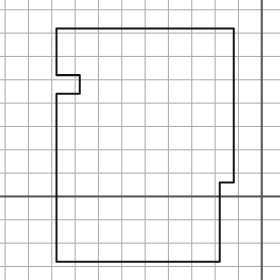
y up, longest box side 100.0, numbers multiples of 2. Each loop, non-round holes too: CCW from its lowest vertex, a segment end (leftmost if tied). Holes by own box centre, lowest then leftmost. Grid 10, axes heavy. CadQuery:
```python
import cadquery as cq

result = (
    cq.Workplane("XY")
    .moveTo(-88.0, -28.0)
    .lineTo(-18.0, -28.0)
    .lineTo(-18.0, 6.0)
    .lineTo(-12.0, 6.0)
    .lineTo(-12.0, 72.0)
    .lineTo(-88.0, 72.0)
    .lineTo(-88.0, 52.0)
    .lineTo(-78.0, 52.0)
    .lineTo(-78.0, 44.0)
    .lineTo(-88.0, 44.0)
    .close()
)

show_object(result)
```